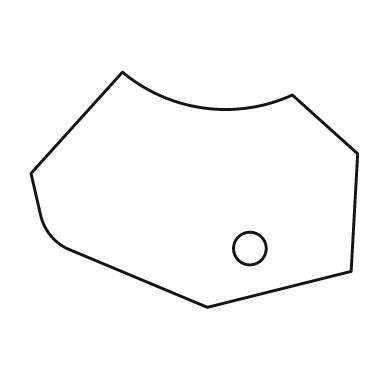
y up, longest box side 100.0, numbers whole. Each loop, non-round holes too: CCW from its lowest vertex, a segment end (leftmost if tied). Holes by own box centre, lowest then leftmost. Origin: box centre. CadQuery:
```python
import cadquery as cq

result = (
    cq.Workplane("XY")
    .moveTo(4.0, -36.0)
    .lineTo(48.0, -25.0)
    .lineTo(50.0, 11.0)
    .lineTo(30.0, 29.0)
    .threePointArc((3.0, 25.0), (-22.0, 36.0))
    .lineTo(-50.0, 5.0)
    .lineTo(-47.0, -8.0)
    .threePointArc((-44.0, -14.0), (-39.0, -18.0))
    .close()
    .moveTo(17.0, -18.0)
    .circle(5.0)
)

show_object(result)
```